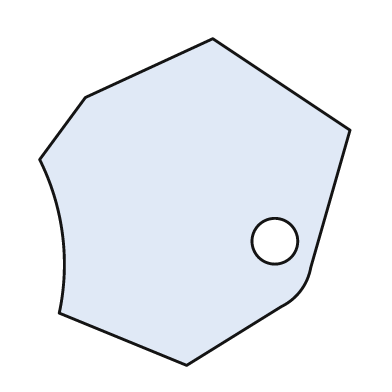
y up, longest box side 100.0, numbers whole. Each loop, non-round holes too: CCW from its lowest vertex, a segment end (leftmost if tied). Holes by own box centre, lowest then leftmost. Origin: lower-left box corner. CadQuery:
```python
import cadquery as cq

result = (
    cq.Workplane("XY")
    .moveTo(45.0, 0.0)
    .lineTo(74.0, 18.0)
    .threePointArc((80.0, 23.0), (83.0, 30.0))
    .lineTo(95.0, 72.0)
    .lineTo(53.0, 100.0)
    .lineTo(14.0, 82.0)
    .lineTo(0.0, 63.0)
    .threePointArc((7.0, 40.0), (6.0, 16.0))
    .close()
    .moveTo(72.0, 38.0)
    .circle(7.0)
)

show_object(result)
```